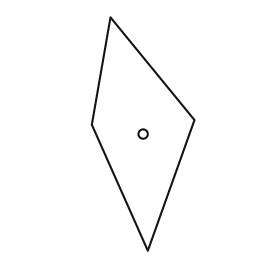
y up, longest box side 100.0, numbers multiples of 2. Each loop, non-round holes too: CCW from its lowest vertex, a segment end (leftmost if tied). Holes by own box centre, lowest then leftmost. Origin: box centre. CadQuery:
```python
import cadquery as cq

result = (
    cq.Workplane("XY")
    .moveTo(2.0, -50.0)
    .lineTo(22.0, 6.0)
    .lineTo(-14.0, 50.0)
    .lineTo(-22.0, 4.0)
    .close()
    .moveTo(0.0, 0.0)
    .circle(2.0)
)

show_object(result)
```